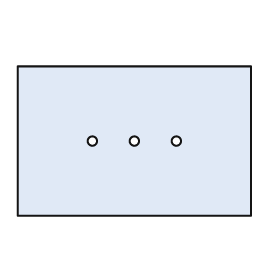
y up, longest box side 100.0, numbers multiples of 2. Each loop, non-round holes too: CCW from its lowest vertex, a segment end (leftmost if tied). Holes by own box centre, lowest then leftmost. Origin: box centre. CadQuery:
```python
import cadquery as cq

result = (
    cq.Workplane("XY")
    .moveTo(-50.0, -32.0)
    .lineTo(50.0, -32.0)
    .lineTo(50.0, 32.0)
    .lineTo(-50.0, 32.0)
    .close()
    .moveTo(-18.0, 0.0)
    .circle(2.0)
    .moveTo(0.0, 0.0)
    .circle(2.0)
    .moveTo(18.0, 0.0)
    .circle(2.0)
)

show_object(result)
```